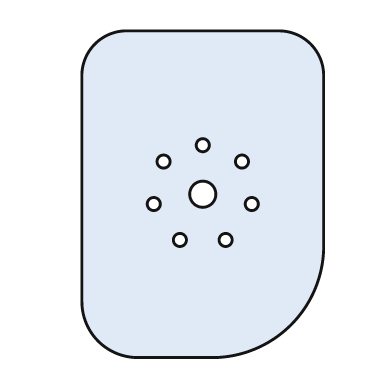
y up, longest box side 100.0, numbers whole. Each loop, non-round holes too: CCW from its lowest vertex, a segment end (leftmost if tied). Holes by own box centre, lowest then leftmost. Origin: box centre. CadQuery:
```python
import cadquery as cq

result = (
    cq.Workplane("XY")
    .moveTo(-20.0, -50.0)
    .lineTo(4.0, -50.0)
    .threePointArc((27.0, -40.0), (37.0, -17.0))
    .lineTo(37.0, 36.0)
    .threePointArc((33.0, 46.0), (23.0, 50.0))
    .lineTo(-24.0, 50.0)
    .threePointArc((-33.0, 46.0), (-37.0, 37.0))
    .lineTo(-37.0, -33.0)
    .threePointArc((-32.0, -45.0), (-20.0, -50.0))
    .close()
    .moveTo(-7.0, -14.0)
    .circle(2.0)
    .moveTo(7.0, -14.0)
    .circle(2.0)
    .moveTo(-15.0, -3.0)
    .circle(2.0)
    .moveTo(15.0, -3.0)
    .circle(2.0)
    .moveTo(0.0, 0.0)
    .circle(4.0)
    .moveTo(-12.0, 10.0)
    .circle(2.0)
    .moveTo(12.0, 10.0)
    .circle(2.0)
    .moveTo(0.0, 15.0)
    .circle(2.0)
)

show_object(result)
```